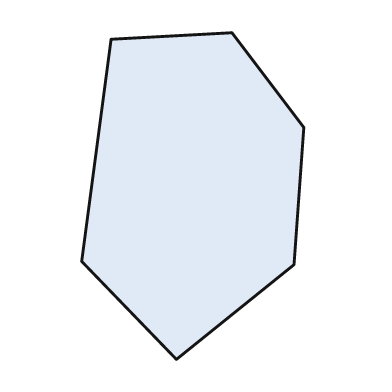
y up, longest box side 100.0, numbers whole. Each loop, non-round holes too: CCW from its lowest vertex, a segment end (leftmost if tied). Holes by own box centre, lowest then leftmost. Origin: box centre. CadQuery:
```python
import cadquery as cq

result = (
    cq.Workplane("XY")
    .moveTo(-5.0, -50.0)
    .lineTo(31.0, -21.0)
    .lineTo(34.0, 21.0)
    .lineTo(12.0, 50.0)
    .lineTo(-25.0, 48.0)
    .lineTo(-34.0, -20.0)
    .close()
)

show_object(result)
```